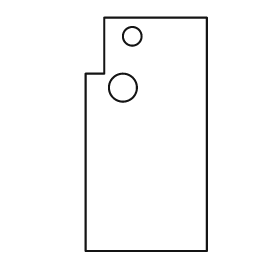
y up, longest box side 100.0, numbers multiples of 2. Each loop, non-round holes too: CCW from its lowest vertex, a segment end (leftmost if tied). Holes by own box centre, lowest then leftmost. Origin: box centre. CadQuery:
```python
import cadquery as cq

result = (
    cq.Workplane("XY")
    .moveTo(-26.0, -50.0)
    .lineTo(26.0, -50.0)
    .lineTo(26.0, 50.0)
    .lineTo(-18.0, 50.0)
    .lineTo(-18.0, 26.0)
    .lineTo(-26.0, 26.0)
    .close()
    .moveTo(-10.0, 20.0)
    .circle(6.0)
    .moveTo(-6.0, 42.0)
    .circle(4.0)
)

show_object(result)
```